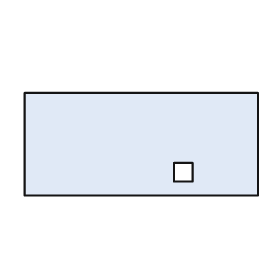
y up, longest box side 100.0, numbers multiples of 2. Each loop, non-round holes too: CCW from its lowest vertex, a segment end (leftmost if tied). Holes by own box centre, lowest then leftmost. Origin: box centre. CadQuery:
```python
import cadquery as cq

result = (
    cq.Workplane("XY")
    .moveTo(-50.0, -22.0)
    .lineTo(50.0, -22.0)
    .lineTo(50.0, 22.0)
    .lineTo(-50.0, 22.0)
    .close()
    .moveTo(14.0, -16.0)
    .lineTo(22.0, -16.0)
    .lineTo(22.0, -8.0)
    .lineTo(14.0, -8.0)
    .close()
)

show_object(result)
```